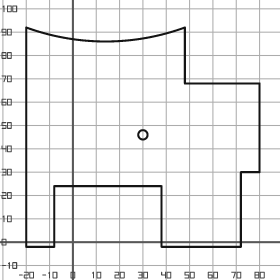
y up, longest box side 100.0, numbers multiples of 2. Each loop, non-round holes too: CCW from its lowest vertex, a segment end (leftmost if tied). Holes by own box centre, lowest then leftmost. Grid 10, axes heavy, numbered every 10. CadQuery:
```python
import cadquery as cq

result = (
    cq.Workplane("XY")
    .moveTo(-20.0, -2.0)
    .lineTo(-8.0, -2.0)
    .lineTo(-8.0, 24.0)
    .lineTo(38.0, 24.0)
    .lineTo(38.0, -2.0)
    .lineTo(72.0, -2.0)
    .lineTo(72.0, 30.0)
    .lineTo(80.0, 30.0)
    .lineTo(80.0, 68.0)
    .lineTo(48.0, 68.0)
    .lineTo(48.0, 92.0)
    .threePointArc((14.0, 86.0), (-20.0, 92.0))
    .close()
    .moveTo(30.0, 46.0)
    .circle(2.0)
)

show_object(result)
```